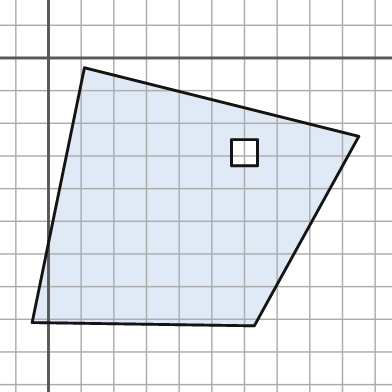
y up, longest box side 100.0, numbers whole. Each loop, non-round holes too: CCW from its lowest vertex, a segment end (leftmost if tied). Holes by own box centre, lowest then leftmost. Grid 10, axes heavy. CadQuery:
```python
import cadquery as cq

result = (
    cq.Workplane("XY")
    .moveTo(63.0, -82.0)
    .lineTo(95.0, -24.0)
    .lineTo(11.0, -3.0)
    .lineTo(-5.0, -81.0)
    .close()
    .moveTo(56.0, -33.0)
    .lineTo(64.0, -33.0)
    .lineTo(64.0, -25.0)
    .lineTo(56.0, -25.0)
    .close()
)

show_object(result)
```